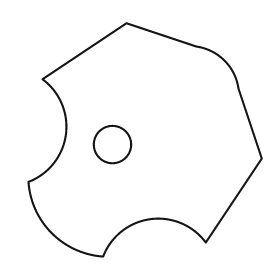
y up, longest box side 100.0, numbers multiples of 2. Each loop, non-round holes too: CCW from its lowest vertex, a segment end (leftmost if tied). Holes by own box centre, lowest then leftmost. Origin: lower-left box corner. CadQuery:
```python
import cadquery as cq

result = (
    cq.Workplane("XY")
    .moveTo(32.0, 0.0)
    .threePointArc((52.0, 16.0), (76.0, 6.0))
    .lineTo(100.0, 42.0)
    .lineTo(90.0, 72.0)
    .threePointArc((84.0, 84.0), (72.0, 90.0))
    .lineTo(42.0, 100.0)
    .lineTo(6.0, 76.0)
    .threePointArc((16.0, 52.0), (0.0, 32.0))
    .threePointArc((10.0, 10.0), (32.0, 0.0))
    .close()
    .moveTo(36.0, 48.0)
    .circle(8.0)
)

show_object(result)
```